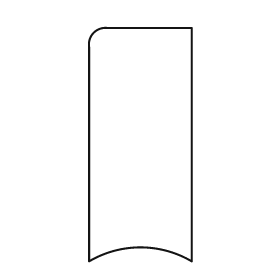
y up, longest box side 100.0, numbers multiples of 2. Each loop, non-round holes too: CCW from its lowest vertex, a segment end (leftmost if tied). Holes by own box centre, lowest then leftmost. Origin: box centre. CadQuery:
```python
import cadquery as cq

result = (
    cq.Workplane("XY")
    .moveTo(-22.0, -50.0)
    .threePointArc((0.0, -44.0), (22.0, -50.0))
    .lineTo(22.0, 50.0)
    .lineTo(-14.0, 50.0)
    .threePointArc((-20.0, 48.0), (-22.0, 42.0))
    .close()
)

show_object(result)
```